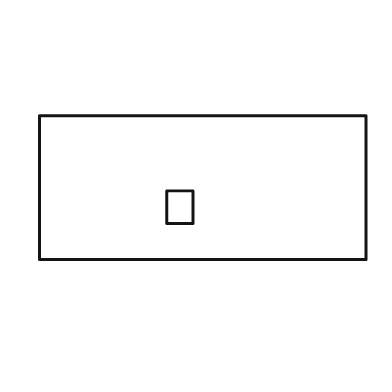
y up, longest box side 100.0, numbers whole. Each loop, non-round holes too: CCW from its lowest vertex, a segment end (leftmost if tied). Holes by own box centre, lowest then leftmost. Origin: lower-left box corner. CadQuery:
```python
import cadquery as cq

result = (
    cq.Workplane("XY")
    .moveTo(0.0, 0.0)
    .lineTo(100.0, 0.0)
    .lineTo(100.0, 44.0)
    .lineTo(0.0, 44.0)
    .close()
    .moveTo(39.0, 11.0)
    .lineTo(47.0, 11.0)
    .lineTo(47.0, 21.0)
    .lineTo(39.0, 21.0)
    .close()
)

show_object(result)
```